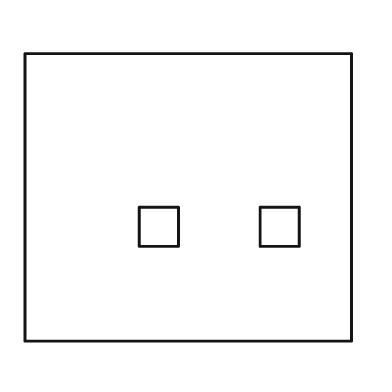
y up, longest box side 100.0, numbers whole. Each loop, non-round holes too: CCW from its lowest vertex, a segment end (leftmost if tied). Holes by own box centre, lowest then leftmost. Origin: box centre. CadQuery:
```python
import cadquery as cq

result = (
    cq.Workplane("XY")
    .moveTo(-50.0, -44.0)
    .lineTo(50.0, -44.0)
    .lineTo(50.0, 44.0)
    .lineTo(-50.0, 44.0)
    .close()
    .moveTo(-15.0, -15.0)
    .lineTo(-3.0, -15.0)
    .lineTo(-3.0, -3.0)
    .lineTo(-15.0, -3.0)
    .close()
    .moveTo(22.0, -15.0)
    .lineTo(34.0, -15.0)
    .lineTo(34.0, -3.0)
    .lineTo(22.0, -3.0)
    .close()
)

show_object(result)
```